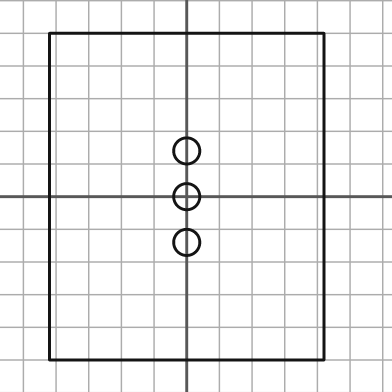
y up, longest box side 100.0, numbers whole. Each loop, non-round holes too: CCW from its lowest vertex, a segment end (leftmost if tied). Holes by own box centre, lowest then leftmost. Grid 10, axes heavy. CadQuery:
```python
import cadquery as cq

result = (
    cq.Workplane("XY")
    .moveTo(-42.0, -50.0)
    .lineTo(42.0, -50.0)
    .lineTo(42.0, 50.0)
    .lineTo(-42.0, 50.0)
    .close()
    .moveTo(0.0, -14.0)
    .circle(4.0)
    .moveTo(0.0, 0.0)
    .circle(4.0)
    .moveTo(0.0, 14.0)
    .circle(4.0)
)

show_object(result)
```